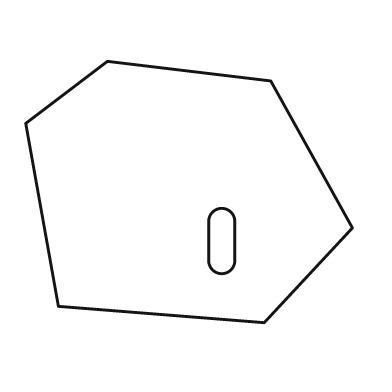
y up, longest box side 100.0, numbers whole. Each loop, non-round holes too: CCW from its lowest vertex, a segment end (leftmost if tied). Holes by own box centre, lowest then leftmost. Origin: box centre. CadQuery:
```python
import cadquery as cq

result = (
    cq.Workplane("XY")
    .moveTo(23.0, -40.0)
    .lineTo(50.0, -11.0)
    .lineTo(25.0, 34.0)
    .lineTo(-25.0, 40.0)
    .lineTo(-50.0, 21.0)
    .lineTo(-40.0, -35.0)
    .close()
    .moveTo(6.0, -21.0)
    .threePointArc((10.0, -25.0), (14.0, -21.0))
    .lineTo(14.0, -9.0)
    .threePointArc((10.0, -5.0), (6.0, -9.0))
    .close()
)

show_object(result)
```